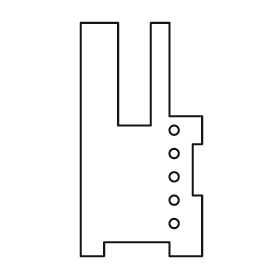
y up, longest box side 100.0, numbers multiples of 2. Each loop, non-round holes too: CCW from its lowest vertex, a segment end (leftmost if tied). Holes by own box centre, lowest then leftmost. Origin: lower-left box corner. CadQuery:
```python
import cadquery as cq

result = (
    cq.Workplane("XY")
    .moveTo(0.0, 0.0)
    .lineTo(10.0, 0.0)
    .lineTo(10.0, 6.0)
    .lineTo(38.0, 6.0)
    .lineTo(38.0, 0.0)
    .lineTo(52.0, 0.0)
    .lineTo(52.0, 26.0)
    .lineTo(48.0, 26.0)
    .lineTo(48.0, 48.0)
    .lineTo(52.0, 48.0)
    .lineTo(52.0, 60.0)
    .lineTo(38.0, 60.0)
    .lineTo(38.0, 100.0)
    .lineTo(30.0, 100.0)
    .lineTo(30.0, 56.0)
    .lineTo(16.0, 56.0)
    .lineTo(16.0, 100.0)
    .lineTo(0.0, 100.0)
    .close()
    .moveTo(40.0, 14.0)
    .circle(2.0)
    .moveTo(40.0, 24.0)
    .circle(2.0)
    .moveTo(40.0, 34.0)
    .circle(2.0)
    .moveTo(40.0, 44.0)
    .circle(2.0)
    .moveTo(40.0, 54.0)
    .circle(2.0)
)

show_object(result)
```